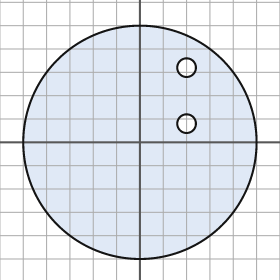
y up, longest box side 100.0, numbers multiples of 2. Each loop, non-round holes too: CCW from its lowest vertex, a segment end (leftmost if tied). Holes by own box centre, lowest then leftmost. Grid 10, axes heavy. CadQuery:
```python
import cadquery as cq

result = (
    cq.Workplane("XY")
    .moveTo(0.0, 0.0)
    .circle(50.0)
    .moveTo(20.0, 8.0)
    .circle(4.0)
    .moveTo(20.0, 32.0)
    .circle(4.0)
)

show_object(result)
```